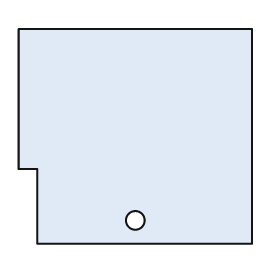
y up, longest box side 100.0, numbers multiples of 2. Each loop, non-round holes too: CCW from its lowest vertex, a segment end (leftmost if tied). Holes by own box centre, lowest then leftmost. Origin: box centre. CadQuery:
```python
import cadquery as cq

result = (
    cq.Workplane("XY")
    .moveTo(-42.0, -46.0)
    .lineTo(50.0, -46.0)
    .lineTo(50.0, 46.0)
    .lineTo(-50.0, 46.0)
    .lineTo(-50.0, -14.0)
    .lineTo(-42.0, -14.0)
    .close()
    .moveTo(0.0, -36.0)
    .circle(4.0)
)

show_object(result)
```